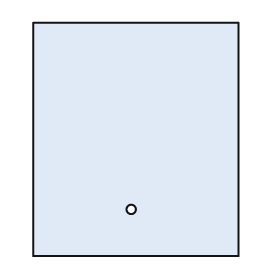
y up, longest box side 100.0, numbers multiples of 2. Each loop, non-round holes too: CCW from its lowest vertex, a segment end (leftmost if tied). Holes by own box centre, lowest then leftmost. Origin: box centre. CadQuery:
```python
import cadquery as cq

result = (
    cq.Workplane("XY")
    .moveTo(-44.0, -50.0)
    .lineTo(44.0, -50.0)
    .lineTo(44.0, 50.0)
    .lineTo(-44.0, 50.0)
    .close()
    .moveTo(-2.0, -30.0)
    .circle(2.0)
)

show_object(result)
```